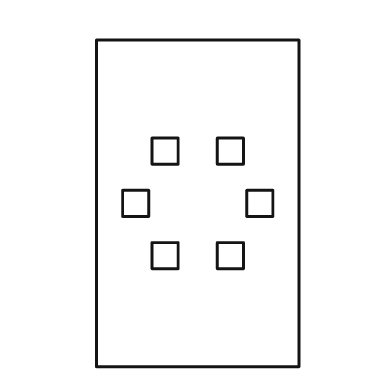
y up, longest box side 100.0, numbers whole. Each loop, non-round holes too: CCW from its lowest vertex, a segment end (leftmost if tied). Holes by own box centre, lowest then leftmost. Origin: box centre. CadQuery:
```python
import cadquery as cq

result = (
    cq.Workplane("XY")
    .moveTo(-31.0, -50.0)
    .lineTo(31.0, -50.0)
    .lineTo(31.0, 50.0)
    .lineTo(-31.0, 50.0)
    .close()
    .moveTo(-14.0, -20.0)
    .lineTo(-6.0, -20.0)
    .lineTo(-6.0, -12.0)
    .lineTo(-14.0, -12.0)
    .close()
    .moveTo(6.0, -20.0)
    .lineTo(14.0, -20.0)
    .lineTo(14.0, -12.0)
    .lineTo(6.0, -12.0)
    .close()
    .moveTo(-23.0, -4.0)
    .lineTo(-15.0, -4.0)
    .lineTo(-15.0, 4.0)
    .lineTo(-23.0, 4.0)
    .close()
    .moveTo(15.0, -4.0)
    .lineTo(23.0, -4.0)
    .lineTo(23.0, 4.0)
    .lineTo(15.0, 4.0)
    .close()
    .moveTo(-14.0, 12.0)
    .lineTo(-6.0, 12.0)
    .lineTo(-6.0, 20.0)
    .lineTo(-14.0, 20.0)
    .close()
    .moveTo(6.0, 12.0)
    .lineTo(14.0, 12.0)
    .lineTo(14.0, 20.0)
    .lineTo(6.0, 20.0)
    .close()
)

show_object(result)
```